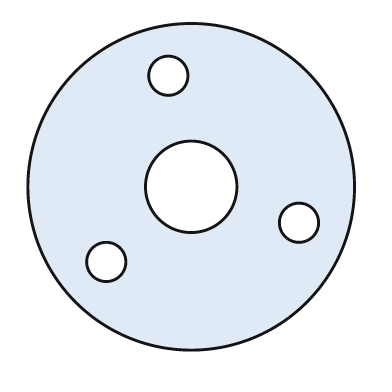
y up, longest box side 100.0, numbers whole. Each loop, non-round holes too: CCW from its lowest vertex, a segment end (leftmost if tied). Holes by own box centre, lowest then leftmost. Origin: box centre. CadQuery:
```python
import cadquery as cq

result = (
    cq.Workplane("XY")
    .moveTo(0.0, 0.0)
    .circle(50.0)
    .moveTo(-26.0, -23.0)
    .circle(6.0)
    .moveTo(33.0, -11.0)
    .circle(6.0)
    .moveTo(0.0, 0.0)
    .circle(14.0)
    .moveTo(-7.0, 34.0)
    .circle(6.0)
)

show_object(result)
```